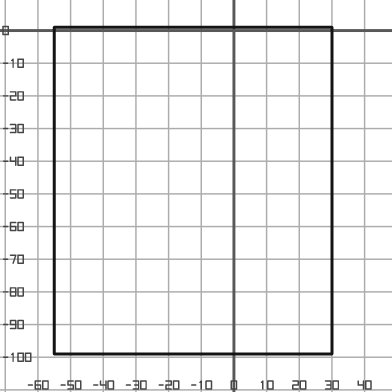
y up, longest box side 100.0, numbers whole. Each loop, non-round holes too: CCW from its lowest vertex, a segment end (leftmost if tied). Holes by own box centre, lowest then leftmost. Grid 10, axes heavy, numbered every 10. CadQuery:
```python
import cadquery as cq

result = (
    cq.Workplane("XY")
    .moveTo(-55.0, -99.0)
    .lineTo(30.0, -99.0)
    .lineTo(30.0, 1.0)
    .lineTo(-55.0, 1.0)
    .close()
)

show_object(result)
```